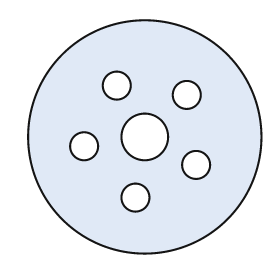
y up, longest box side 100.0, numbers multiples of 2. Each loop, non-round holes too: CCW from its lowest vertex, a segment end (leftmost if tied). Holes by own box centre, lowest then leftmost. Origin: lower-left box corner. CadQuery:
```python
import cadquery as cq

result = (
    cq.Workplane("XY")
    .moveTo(50.0, 50.0)
    .circle(50.0)
    .moveTo(46.0, 24.0)
    .circle(6.0)
    .moveTo(72.0, 38.0)
    .circle(6.0)
    .moveTo(24.0, 46.0)
    .circle(6.0)
    .moveTo(50.0, 50.0)
    .circle(10.0)
    .moveTo(68.0, 68.0)
    .circle(6.0)
    .moveTo(38.0, 72.0)
    .circle(6.0)
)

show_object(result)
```